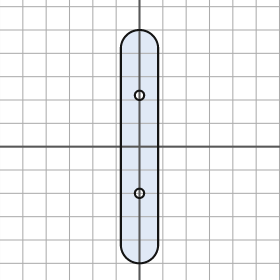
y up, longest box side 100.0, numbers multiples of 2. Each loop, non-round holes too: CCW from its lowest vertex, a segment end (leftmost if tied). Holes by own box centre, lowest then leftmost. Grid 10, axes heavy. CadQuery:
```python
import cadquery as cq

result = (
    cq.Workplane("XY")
    .moveTo(-8.0, -42.0)
    .threePointArc((0.0, -50.0), (8.0, -42.0))
    .lineTo(8.0, 42.0)
    .threePointArc((0.0, 50.0), (-8.0, 42.0))
    .close()
    .moveTo(0.0, -20.0)
    .circle(2.0)
    .moveTo(0.0, 22.0)
    .circle(2.0)
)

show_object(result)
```